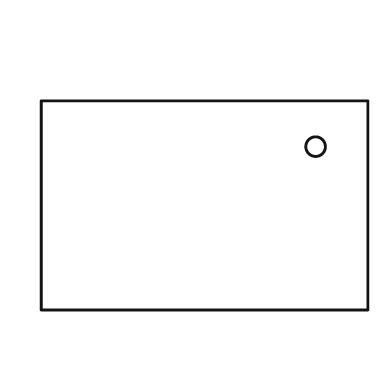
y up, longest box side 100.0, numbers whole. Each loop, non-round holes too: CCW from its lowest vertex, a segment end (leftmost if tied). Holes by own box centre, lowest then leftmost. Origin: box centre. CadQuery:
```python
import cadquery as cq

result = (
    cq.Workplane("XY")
    .moveTo(-50.0, -32.0)
    .lineTo(50.0, -32.0)
    .lineTo(50.0, 32.0)
    .lineTo(-50.0, 32.0)
    .close()
    .moveTo(34.0, 18.0)
    .circle(3.0)
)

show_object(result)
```